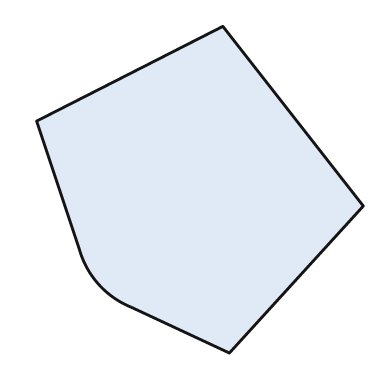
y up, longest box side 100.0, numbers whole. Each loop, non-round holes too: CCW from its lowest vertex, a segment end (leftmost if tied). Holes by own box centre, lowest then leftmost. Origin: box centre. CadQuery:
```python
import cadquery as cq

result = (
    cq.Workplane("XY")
    .moveTo(9.0, -50.0)
    .lineTo(50.0, -5.0)
    .lineTo(7.0, 50.0)
    .lineTo(-50.0, 21.0)
    .lineTo(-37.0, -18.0)
    .threePointArc((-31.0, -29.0), (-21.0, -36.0))
    .close()
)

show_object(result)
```